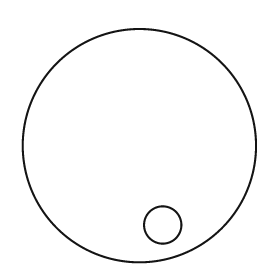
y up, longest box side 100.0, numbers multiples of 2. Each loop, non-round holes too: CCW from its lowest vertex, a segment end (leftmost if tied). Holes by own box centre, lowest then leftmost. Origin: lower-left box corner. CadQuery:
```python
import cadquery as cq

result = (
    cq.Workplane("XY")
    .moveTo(50.0, 50.0)
    .circle(50.0)
    .moveTo(60.0, 16.0)
    .circle(8.0)
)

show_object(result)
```